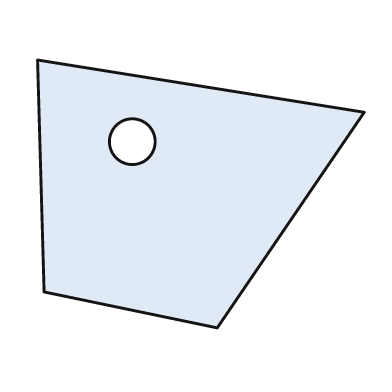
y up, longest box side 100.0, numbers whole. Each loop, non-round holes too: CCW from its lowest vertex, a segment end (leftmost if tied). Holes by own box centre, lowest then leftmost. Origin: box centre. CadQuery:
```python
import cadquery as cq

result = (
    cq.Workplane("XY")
    .moveTo(5.0, -41.0)
    .lineTo(50.0, 25.0)
    .lineTo(-50.0, 41.0)
    .lineTo(-48.0, -30.0)
    .close()
    .moveTo(-21.0, 16.0)
    .circle(7.0)
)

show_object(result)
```